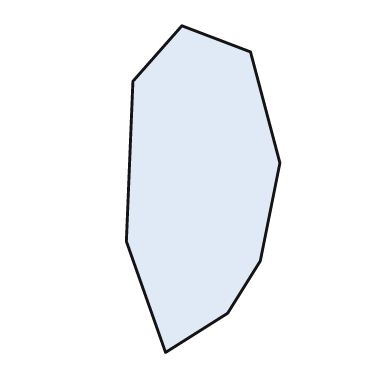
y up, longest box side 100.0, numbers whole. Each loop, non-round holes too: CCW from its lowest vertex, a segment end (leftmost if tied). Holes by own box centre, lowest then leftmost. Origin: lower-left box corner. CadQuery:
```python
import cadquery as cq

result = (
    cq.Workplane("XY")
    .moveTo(12.0, 0.0)
    .lineTo(31.0, 12.0)
    .lineTo(41.0, 28.0)
    .lineTo(47.0, 58.0)
    .lineTo(38.0, 92.0)
    .lineTo(17.0, 100.0)
    .lineTo(2.0, 83.0)
    .lineTo(0.0, 34.0)
    .close()
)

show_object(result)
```